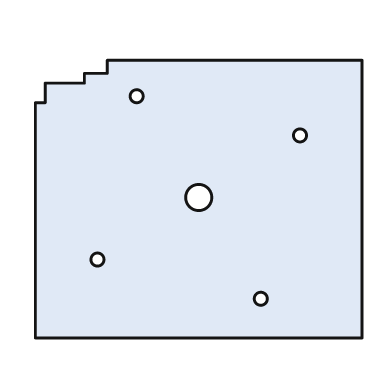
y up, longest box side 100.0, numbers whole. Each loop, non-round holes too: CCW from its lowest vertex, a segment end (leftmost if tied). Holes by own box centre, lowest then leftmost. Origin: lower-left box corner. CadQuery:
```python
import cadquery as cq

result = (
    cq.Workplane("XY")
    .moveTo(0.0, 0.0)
    .lineTo(100.0, 0.0)
    .lineTo(100.0, 85.0)
    .lineTo(22.0, 85.0)
    .lineTo(22.0, 81.0)
    .lineTo(15.0, 81.0)
    .lineTo(15.0, 78.0)
    .lineTo(3.0, 78.0)
    .lineTo(3.0, 72.0)
    .lineTo(0.0, 72.0)
    .close()
    .moveTo(69.0, 12.0)
    .circle(2.0)
    .moveTo(19.0, 24.0)
    .circle(2.0)
    .moveTo(50.0, 43.0)
    .circle(4.0)
    .moveTo(81.0, 62.0)
    .circle(2.0)
    .moveTo(31.0, 74.0)
    .circle(2.0)
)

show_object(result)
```